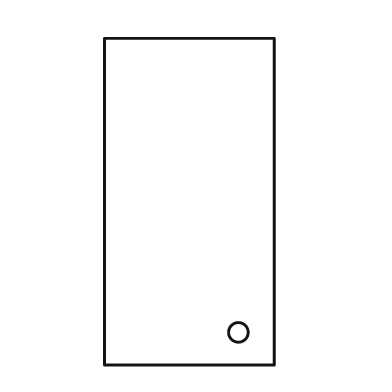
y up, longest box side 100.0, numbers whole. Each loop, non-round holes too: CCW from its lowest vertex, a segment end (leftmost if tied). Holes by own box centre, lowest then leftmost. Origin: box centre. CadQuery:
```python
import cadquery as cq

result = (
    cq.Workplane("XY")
    .moveTo(-26.0, -50.0)
    .lineTo(26.0, -50.0)
    .lineTo(26.0, 50.0)
    .lineTo(-26.0, 50.0)
    .close()
    .moveTo(15.0, -40.0)
    .circle(3.0)
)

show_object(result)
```